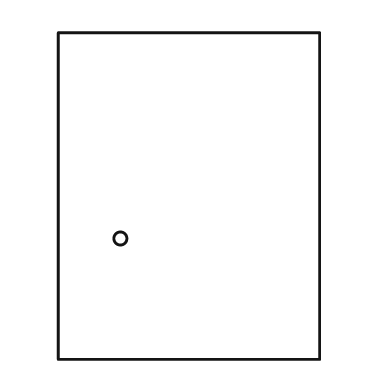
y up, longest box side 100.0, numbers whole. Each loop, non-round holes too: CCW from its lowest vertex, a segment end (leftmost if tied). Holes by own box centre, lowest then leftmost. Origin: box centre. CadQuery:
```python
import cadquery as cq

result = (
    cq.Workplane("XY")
    .moveTo(-40.0, -50.0)
    .lineTo(40.0, -50.0)
    .lineTo(40.0, 50.0)
    .lineTo(-40.0, 50.0)
    .close()
    .moveTo(-21.0, -13.0)
    .circle(2.0)
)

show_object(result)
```